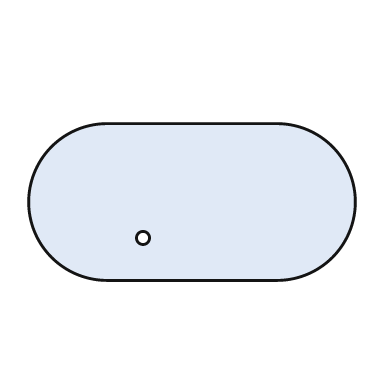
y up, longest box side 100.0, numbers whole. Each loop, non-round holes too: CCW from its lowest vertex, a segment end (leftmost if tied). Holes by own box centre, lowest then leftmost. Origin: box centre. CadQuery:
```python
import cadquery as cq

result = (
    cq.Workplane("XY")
    .moveTo(-26.0, -24.0)
    .lineTo(26.0, -24.0)
    .threePointArc((50.0, 0.0), (26.0, 24.0))
    .lineTo(-26.0, 24.0)
    .threePointArc((-50.0, 0.0), (-26.0, -24.0))
    .close()
    .moveTo(-15.0, -11.0)
    .circle(2.0)
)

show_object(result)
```